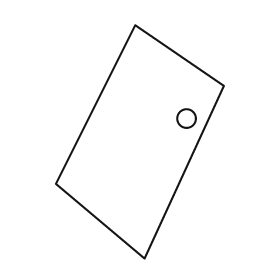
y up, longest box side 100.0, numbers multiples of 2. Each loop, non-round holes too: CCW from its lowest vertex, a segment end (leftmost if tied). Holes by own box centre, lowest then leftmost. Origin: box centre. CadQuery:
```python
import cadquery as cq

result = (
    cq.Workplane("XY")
    .moveTo(2.0, -50.0)
    .lineTo(36.0, 24.0)
    .lineTo(-2.0, 50.0)
    .lineTo(-36.0, -18.0)
    .close()
    .moveTo(20.0, 10.0)
    .circle(4.0)
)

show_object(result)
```